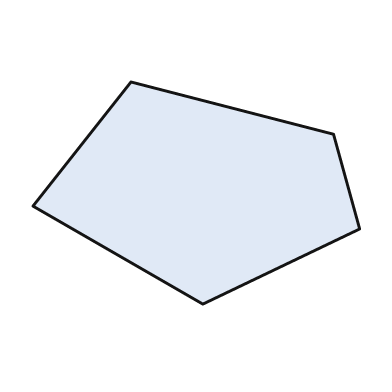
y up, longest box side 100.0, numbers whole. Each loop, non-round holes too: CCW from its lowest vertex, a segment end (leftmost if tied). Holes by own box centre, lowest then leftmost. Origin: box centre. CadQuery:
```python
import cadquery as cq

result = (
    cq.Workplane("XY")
    .moveTo(2.0, -34.0)
    .lineTo(50.0, -11.0)
    .lineTo(42.0, 18.0)
    .lineTo(-20.0, 34.0)
    .lineTo(-50.0, -4.0)
    .close()
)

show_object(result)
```